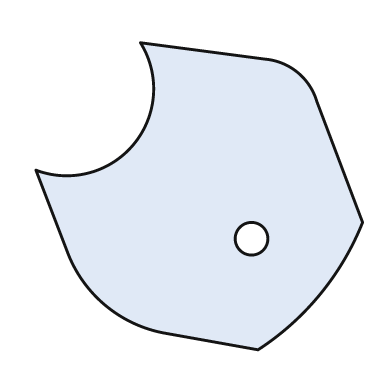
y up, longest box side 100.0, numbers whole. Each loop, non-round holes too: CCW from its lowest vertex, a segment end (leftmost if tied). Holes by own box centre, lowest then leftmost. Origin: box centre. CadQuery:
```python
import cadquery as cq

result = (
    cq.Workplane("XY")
    .moveTo(18.0, -47.0)
    .threePointArc((37.0, -30.0), (50.0, -8.0))
    .lineTo(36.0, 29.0)
    .threePointArc((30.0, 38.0), (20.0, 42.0))
    .lineTo(-18.0, 47.0)
    .threePointArc((-20.0, 16.0), (-50.0, 8.0))
    .lineTo(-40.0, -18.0)
    .threePointArc((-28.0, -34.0), (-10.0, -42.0))
    .close()
    .moveTo(16.0, -13.0)
    .circle(5.0)
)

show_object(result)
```